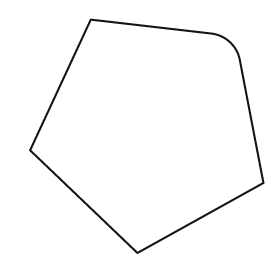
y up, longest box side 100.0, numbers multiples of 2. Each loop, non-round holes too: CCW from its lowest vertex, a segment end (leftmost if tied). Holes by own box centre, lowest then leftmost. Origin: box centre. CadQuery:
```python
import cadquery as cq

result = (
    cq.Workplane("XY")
    .moveTo(-4.0, -50.0)
    .lineTo(50.0, -20.0)
    .lineTo(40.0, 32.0)
    .threePointArc((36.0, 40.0), (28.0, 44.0))
    .lineTo(-24.0, 50.0)
    .lineTo(-50.0, -6.0)
    .close()
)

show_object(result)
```